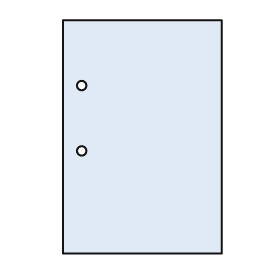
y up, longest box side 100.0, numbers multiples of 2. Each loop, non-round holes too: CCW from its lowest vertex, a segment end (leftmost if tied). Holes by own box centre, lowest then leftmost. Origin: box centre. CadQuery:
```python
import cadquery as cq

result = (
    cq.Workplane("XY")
    .moveTo(-34.0, -50.0)
    .lineTo(34.0, -50.0)
    .lineTo(34.0, 50.0)
    .lineTo(-34.0, 50.0)
    .close()
    .moveTo(-26.0, -6.0)
    .circle(2.0)
    .moveTo(-26.0, 22.0)
    .circle(2.0)
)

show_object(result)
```